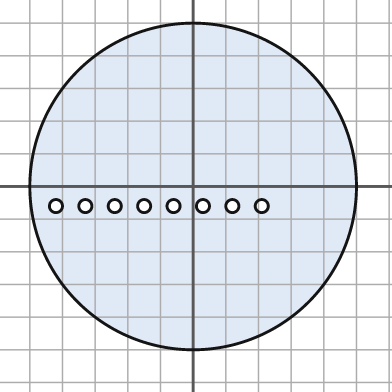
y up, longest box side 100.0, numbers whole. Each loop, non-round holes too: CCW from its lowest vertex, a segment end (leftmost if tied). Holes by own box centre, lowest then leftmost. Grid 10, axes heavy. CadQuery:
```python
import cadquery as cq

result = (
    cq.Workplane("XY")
    .moveTo(0.0, 0.0)
    .circle(50.0)
    .moveTo(-42.0, -6.0)
    .circle(2.0)
    .moveTo(-33.0, -6.0)
    .circle(2.0)
    .moveTo(-24.0, -6.0)
    .circle(2.0)
    .moveTo(-15.0, -6.0)
    .circle(2.0)
    .moveTo(-6.0, -6.0)
    .circle(2.0)
    .moveTo(3.0, -6.0)
    .circle(2.0)
    .moveTo(12.0, -6.0)
    .circle(2.0)
    .moveTo(21.0, -6.0)
    .circle(2.0)
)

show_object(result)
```